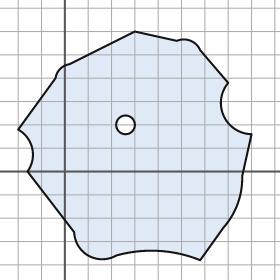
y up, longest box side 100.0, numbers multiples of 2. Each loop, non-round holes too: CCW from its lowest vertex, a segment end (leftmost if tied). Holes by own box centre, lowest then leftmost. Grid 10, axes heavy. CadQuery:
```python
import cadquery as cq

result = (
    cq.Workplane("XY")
    .moveTo(58.0, -38.0)
    .lineTo(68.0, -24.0)
    .threePointArc((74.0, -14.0), (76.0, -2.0))
    .lineTo(80.0, 16.0)
    .threePointArc((68.0, 24.0), (70.0, 38.0))
    .lineTo(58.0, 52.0)
    .threePointArc((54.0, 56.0), (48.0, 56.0))
    .lineTo(30.0, 60.0)
    .lineTo(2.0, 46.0)
    .threePointArc((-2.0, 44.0), (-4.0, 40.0))
    .lineTo(-20.0, 18.0)
    .threePointArc((-14.0, 10.0), (-16.0, 0.0))
    .lineTo(4.0, -26.0)
    .threePointArc((10.0, -36.0), (22.0, -36.0))
    .threePointArc((40.0, -34.0), (58.0, -38.0))
    .close()
    .moveTo(26.0, 20.0)
    .circle(4.0)
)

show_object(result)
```